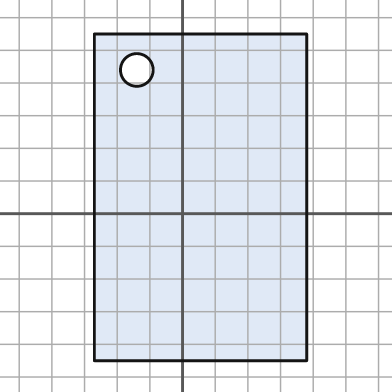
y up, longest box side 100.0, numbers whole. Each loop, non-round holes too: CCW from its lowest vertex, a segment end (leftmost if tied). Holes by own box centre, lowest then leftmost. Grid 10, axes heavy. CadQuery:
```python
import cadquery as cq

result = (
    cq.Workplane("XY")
    .moveTo(-27.0, -45.0)
    .lineTo(38.0, -45.0)
    .lineTo(38.0, 55.0)
    .lineTo(-27.0, 55.0)
    .close()
    .moveTo(-14.0, 44.0)
    .circle(5.0)
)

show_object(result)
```